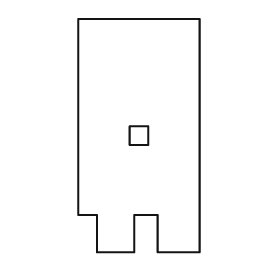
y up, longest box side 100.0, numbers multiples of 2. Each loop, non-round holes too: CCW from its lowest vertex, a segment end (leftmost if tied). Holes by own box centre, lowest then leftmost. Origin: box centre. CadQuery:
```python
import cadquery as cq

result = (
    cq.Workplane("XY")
    .moveTo(-18.0, -50.0)
    .lineTo(-2.0, -50.0)
    .lineTo(-2.0, -34.0)
    .lineTo(8.0, -34.0)
    .lineTo(8.0, -50.0)
    .lineTo(26.0, -50.0)
    .lineTo(26.0, 50.0)
    .lineTo(-26.0, 50.0)
    .lineTo(-26.0, -34.0)
    .lineTo(-18.0, -34.0)
    .close()
    .moveTo(-4.0, -4.0)
    .lineTo(4.0, -4.0)
    .lineTo(4.0, 4.0)
    .lineTo(-4.0, 4.0)
    .close()
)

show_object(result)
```